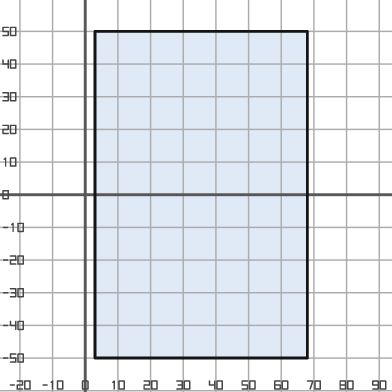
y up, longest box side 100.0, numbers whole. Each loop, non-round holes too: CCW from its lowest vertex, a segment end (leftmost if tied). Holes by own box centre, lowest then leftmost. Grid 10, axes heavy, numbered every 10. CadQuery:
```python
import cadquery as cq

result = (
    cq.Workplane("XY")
    .moveTo(3.0, -50.0)
    .lineTo(68.0, -50.0)
    .lineTo(68.0, 50.0)
    .lineTo(3.0, 50.0)
    .close()
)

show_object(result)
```